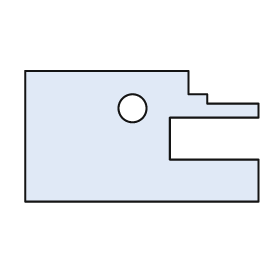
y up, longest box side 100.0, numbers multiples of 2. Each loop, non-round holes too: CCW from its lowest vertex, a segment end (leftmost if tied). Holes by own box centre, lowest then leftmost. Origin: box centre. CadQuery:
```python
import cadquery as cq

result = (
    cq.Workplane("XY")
    .moveTo(-50.0, -28.0)
    .lineTo(50.0, -28.0)
    .lineTo(50.0, -10.0)
    .lineTo(12.0, -10.0)
    .lineTo(12.0, 8.0)
    .lineTo(50.0, 8.0)
    .lineTo(50.0, 14.0)
    .lineTo(28.0, 14.0)
    .lineTo(28.0, 18.0)
    .lineTo(20.0, 18.0)
    .lineTo(20.0, 28.0)
    .lineTo(-50.0, 28.0)
    .close()
    .moveTo(-4.0, 12.0)
    .circle(6.0)
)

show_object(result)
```